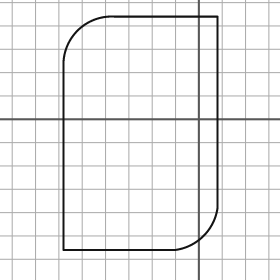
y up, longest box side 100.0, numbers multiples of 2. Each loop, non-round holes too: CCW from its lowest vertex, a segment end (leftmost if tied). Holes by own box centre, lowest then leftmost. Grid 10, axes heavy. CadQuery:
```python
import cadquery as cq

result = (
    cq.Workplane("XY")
    .moveTo(-58.0, -56.0)
    .lineTo(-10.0, -56.0)
    .threePointArc((2.0, -50.0), (8.0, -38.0))
    .lineTo(8.0, 44.0)
    .lineTo(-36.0, 44.0)
    .threePointArc((-52.0, 38.0), (-58.0, 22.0))
    .close()
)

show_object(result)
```